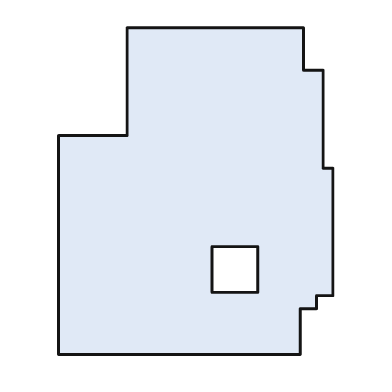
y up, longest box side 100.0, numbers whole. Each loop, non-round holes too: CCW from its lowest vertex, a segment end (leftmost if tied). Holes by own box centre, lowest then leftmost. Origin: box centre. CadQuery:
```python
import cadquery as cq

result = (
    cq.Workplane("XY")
    .moveTo(-42.0, -50.0)
    .lineTo(32.0, -50.0)
    .lineTo(32.0, -36.0)
    .lineTo(37.0, -36.0)
    .lineTo(37.0, -32.0)
    .lineTo(42.0, -32.0)
    .lineTo(42.0, 7.0)
    .lineTo(39.0, 7.0)
    .lineTo(39.0, 37.0)
    .lineTo(33.0, 37.0)
    .lineTo(33.0, 50.0)
    .lineTo(-21.0, 50.0)
    .lineTo(-21.0, 17.0)
    .lineTo(-42.0, 17.0)
    .close()
    .moveTo(5.0, -31.0)
    .lineTo(19.0, -31.0)
    .lineTo(19.0, -17.0)
    .lineTo(5.0, -17.0)
    .close()
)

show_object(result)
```